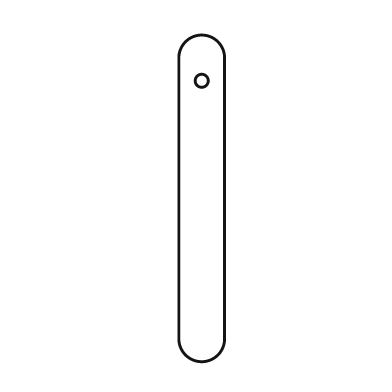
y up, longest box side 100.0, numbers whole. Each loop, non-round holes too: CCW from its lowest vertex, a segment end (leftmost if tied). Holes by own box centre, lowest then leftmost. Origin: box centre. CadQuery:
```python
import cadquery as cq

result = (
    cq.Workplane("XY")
    .moveTo(-7.0, -43.0)
    .threePointArc((0.0, -50.0), (7.0, -43.0))
    .lineTo(7.0, 43.0)
    .threePointArc((0.0, 50.0), (-7.0, 43.0))
    .close()
    .moveTo(0.0, 36.0)
    .circle(2.0)
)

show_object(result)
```